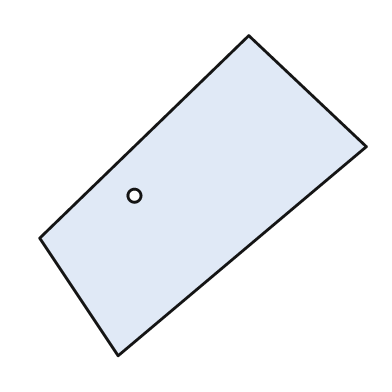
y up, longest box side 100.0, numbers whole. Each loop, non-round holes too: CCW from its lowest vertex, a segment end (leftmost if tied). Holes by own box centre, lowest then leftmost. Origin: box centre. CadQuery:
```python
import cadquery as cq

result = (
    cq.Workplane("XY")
    .moveTo(-26.0, -49.0)
    .lineTo(50.0, 15.0)
    .lineTo(14.0, 49.0)
    .lineTo(-50.0, -13.0)
    .close()
    .moveTo(-21.0, 0.0)
    .circle(2.0)
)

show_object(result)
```